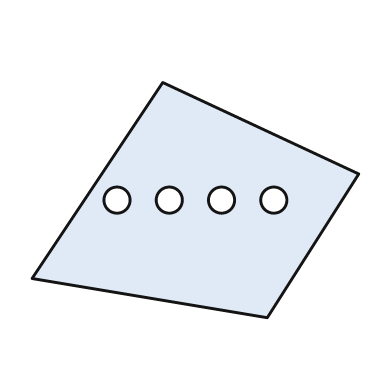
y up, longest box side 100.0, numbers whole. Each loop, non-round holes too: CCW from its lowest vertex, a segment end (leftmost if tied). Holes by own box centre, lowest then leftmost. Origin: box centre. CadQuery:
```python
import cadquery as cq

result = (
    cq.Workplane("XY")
    .moveTo(22.0, -36.0)
    .lineTo(50.0, 8.0)
    .lineTo(-10.0, 36.0)
    .lineTo(-50.0, -24.0)
    .close()
    .moveTo(-24.0, 0.0)
    .circle(4.0)
    .moveTo(-8.0, 0.0)
    .circle(4.0)
    .moveTo(8.0, 0.0)
    .circle(4.0)
    .moveTo(24.0, 0.0)
    .circle(4.0)
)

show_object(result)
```